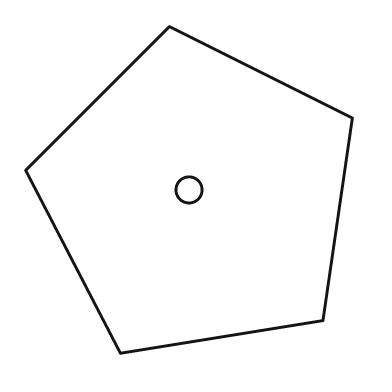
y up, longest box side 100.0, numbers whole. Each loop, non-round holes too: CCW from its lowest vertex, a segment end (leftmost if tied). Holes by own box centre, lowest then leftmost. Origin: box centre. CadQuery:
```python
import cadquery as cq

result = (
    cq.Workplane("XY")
    .moveTo(-21.0, -50.0)
    .lineTo(41.0, -40.0)
    .lineTo(50.0, 22.0)
    .lineTo(-6.0, 50.0)
    .lineTo(-50.0, 6.0)
    .close()
    .moveTo(0.0, 0.0)
    .circle(4.0)
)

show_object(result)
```